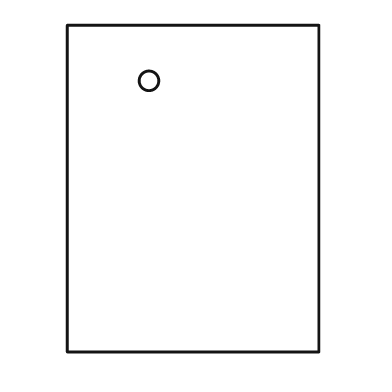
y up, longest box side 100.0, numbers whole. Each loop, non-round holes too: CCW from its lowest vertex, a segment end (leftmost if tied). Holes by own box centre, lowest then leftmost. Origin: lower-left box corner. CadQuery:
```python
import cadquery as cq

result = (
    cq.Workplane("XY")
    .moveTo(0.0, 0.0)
    .lineTo(77.0, 0.0)
    .lineTo(77.0, 100.0)
    .lineTo(0.0, 100.0)
    .close()
    .moveTo(25.0, 83.0)
    .circle(3.0)
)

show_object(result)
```